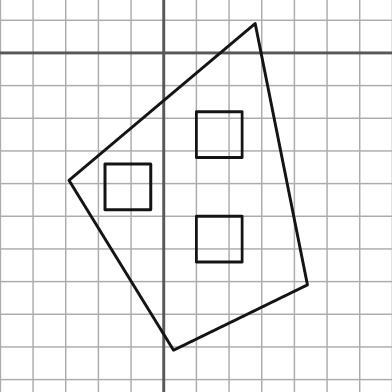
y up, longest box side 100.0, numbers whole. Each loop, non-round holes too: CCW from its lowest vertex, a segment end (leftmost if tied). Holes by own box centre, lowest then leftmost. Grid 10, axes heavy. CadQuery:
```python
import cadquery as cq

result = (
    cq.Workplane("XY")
    .moveTo(3.0, -91.0)
    .lineTo(44.0, -71.0)
    .lineTo(28.0, 9.0)
    .lineTo(-29.0, -39.0)
    .close()
    .moveTo(10.0, -64.0)
    .lineTo(24.0, -64.0)
    .lineTo(24.0, -50.0)
    .lineTo(10.0, -50.0)
    .close()
    .moveTo(-18.0, -48.0)
    .lineTo(-4.0, -48.0)
    .lineTo(-4.0, -34.0)
    .lineTo(-18.0, -34.0)
    .close()
    .moveTo(10.0, -32.0)
    .lineTo(24.0, -32.0)
    .lineTo(24.0, -18.0)
    .lineTo(10.0, -18.0)
    .close()
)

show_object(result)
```